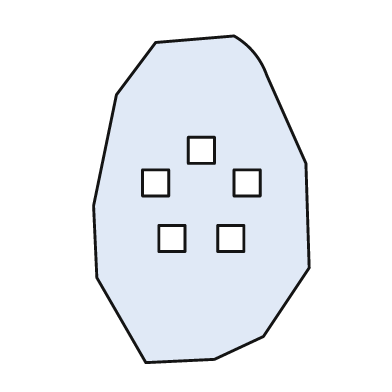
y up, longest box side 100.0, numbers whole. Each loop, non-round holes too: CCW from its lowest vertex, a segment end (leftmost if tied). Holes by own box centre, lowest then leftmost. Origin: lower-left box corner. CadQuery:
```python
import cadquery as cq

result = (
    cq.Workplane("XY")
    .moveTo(16.0, 0.0)
    .lineTo(37.0, 1.0)
    .lineTo(52.0, 8.0)
    .lineTo(66.0, 29.0)
    .lineTo(65.0, 61.0)
    .lineTo(53.0, 88.0)
    .threePointArc((49.0, 95.0), (43.0, 100.0))
    .lineTo(19.0, 98.0)
    .lineTo(7.0, 82.0)
    .lineTo(0.0, 48.0)
    .lineTo(1.0, 26.0)
    .close()
    .moveTo(20.0, 34.0)
    .lineTo(28.0, 34.0)
    .lineTo(28.0, 42.0)
    .lineTo(20.0, 42.0)
    .close()
    .moveTo(38.0, 34.0)
    .lineTo(46.0, 34.0)
    .lineTo(46.0, 42.0)
    .lineTo(38.0, 42.0)
    .close()
    .moveTo(15.0, 51.0)
    .lineTo(23.0, 51.0)
    .lineTo(23.0, 59.0)
    .lineTo(15.0, 59.0)
    .close()
    .moveTo(43.0, 51.0)
    .lineTo(51.0, 51.0)
    .lineTo(51.0, 59.0)
    .lineTo(43.0, 59.0)
    .close()
    .moveTo(29.0, 61.0)
    .lineTo(37.0, 61.0)
    .lineTo(37.0, 69.0)
    .lineTo(29.0, 69.0)
    .close()
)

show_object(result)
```